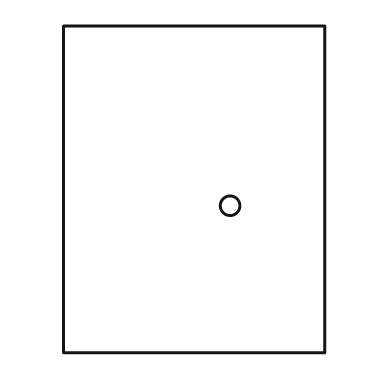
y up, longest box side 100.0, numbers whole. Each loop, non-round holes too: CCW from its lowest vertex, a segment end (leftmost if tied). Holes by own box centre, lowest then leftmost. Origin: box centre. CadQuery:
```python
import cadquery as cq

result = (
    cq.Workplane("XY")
    .moveTo(-40.0, -50.0)
    .lineTo(40.0, -50.0)
    .lineTo(40.0, 50.0)
    .lineTo(-40.0, 50.0)
    .close()
    .moveTo(11.0, -5.0)
    .circle(3.0)
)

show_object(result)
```